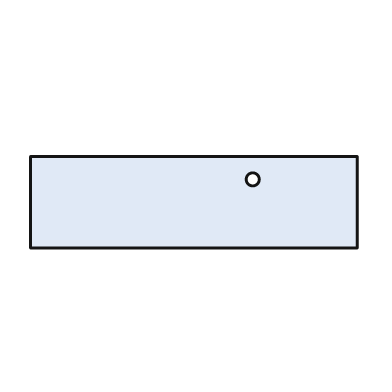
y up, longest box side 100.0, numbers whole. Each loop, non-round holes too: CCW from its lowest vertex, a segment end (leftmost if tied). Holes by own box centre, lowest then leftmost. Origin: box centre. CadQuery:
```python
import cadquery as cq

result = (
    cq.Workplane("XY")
    .moveTo(-50.0, -14.0)
    .lineTo(50.0, -14.0)
    .lineTo(50.0, 14.0)
    .lineTo(-50.0, 14.0)
    .close()
    .moveTo(18.0, 7.0)
    .circle(2.0)
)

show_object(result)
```